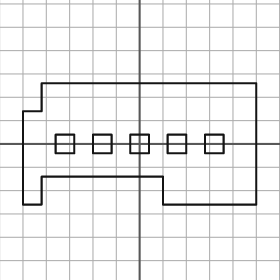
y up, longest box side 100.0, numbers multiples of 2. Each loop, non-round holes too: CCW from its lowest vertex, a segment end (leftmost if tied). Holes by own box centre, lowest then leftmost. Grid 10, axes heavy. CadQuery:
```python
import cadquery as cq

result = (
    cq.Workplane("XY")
    .moveTo(-50.0, -26.0)
    .lineTo(-42.0, -26.0)
    .lineTo(-42.0, -14.0)
    .lineTo(10.0, -14.0)
    .lineTo(10.0, -26.0)
    .lineTo(50.0, -26.0)
    .lineTo(50.0, 26.0)
    .lineTo(-42.0, 26.0)
    .lineTo(-42.0, 14.0)
    .lineTo(-50.0, 14.0)
    .close()
    .moveTo(-36.0, -4.0)
    .lineTo(-28.0, -4.0)
    .lineTo(-28.0, 4.0)
    .lineTo(-36.0, 4.0)
    .close()
    .moveTo(-20.0, -4.0)
    .lineTo(-12.0, -4.0)
    .lineTo(-12.0, 4.0)
    .lineTo(-20.0, 4.0)
    .close()
    .moveTo(-4.0, -4.0)
    .lineTo(4.0, -4.0)
    .lineTo(4.0, 4.0)
    .lineTo(-4.0, 4.0)
    .close()
    .moveTo(12.0, -4.0)
    .lineTo(20.0, -4.0)
    .lineTo(20.0, 4.0)
    .lineTo(12.0, 4.0)
    .close()
    .moveTo(28.0, -4.0)
    .lineTo(36.0, -4.0)
    .lineTo(36.0, 4.0)
    .lineTo(28.0, 4.0)
    .close()
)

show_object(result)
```